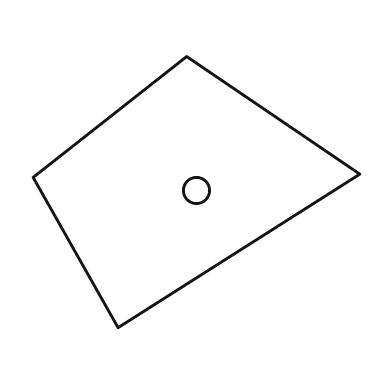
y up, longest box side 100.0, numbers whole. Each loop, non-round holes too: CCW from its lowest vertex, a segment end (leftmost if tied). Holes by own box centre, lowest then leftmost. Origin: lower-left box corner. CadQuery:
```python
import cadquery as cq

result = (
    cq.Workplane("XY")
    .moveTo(26.0, 0.0)
    .lineTo(100.0, 47.0)
    .lineTo(47.0, 83.0)
    .lineTo(0.0, 46.0)
    .close()
    .moveTo(50.0, 42.0)
    .circle(4.0)
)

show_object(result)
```